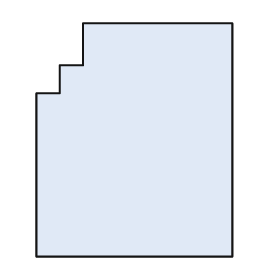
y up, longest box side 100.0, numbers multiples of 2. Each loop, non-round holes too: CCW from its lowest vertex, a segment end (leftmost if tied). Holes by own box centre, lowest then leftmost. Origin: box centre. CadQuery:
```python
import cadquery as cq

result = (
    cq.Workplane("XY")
    .moveTo(-42.0, -50.0)
    .lineTo(42.0, -50.0)
    .lineTo(42.0, 50.0)
    .lineTo(-22.0, 50.0)
    .lineTo(-22.0, 32.0)
    .lineTo(-32.0, 32.0)
    .lineTo(-32.0, 20.0)
    .lineTo(-42.0, 20.0)
    .close()
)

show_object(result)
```